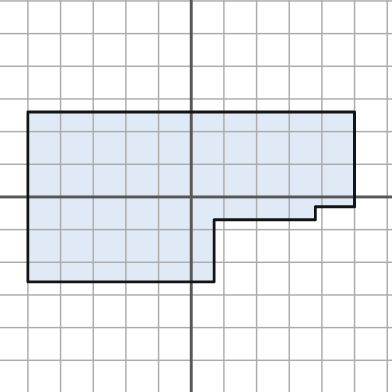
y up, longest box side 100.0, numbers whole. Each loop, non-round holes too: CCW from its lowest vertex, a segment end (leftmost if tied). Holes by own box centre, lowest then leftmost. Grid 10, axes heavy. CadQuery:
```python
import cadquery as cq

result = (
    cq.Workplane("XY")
    .moveTo(-50.0, -26.0)
    .lineTo(7.0, -26.0)
    .lineTo(7.0, -7.0)
    .lineTo(38.0, -7.0)
    .lineTo(38.0, -3.0)
    .lineTo(50.0, -3.0)
    .lineTo(50.0, 26.0)
    .lineTo(-50.0, 26.0)
    .close()
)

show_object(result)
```